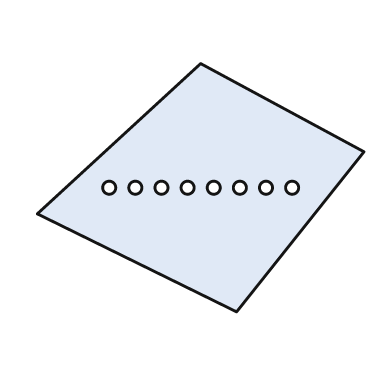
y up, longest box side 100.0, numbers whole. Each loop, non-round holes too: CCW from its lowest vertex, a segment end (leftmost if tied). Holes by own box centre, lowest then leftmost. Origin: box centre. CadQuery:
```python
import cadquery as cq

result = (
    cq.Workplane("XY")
    .moveTo(11.0, -38.0)
    .lineTo(50.0, 11.0)
    .lineTo(0.0, 38.0)
    .lineTo(-50.0, -8.0)
    .close()
    .moveTo(-28.0, 0.0)
    .circle(2.0)
    .moveTo(-20.0, 0.0)
    .circle(2.0)
    .moveTo(-12.0, 0.0)
    .circle(2.0)
    .moveTo(-4.0, 0.0)
    .circle(2.0)
    .moveTo(4.0, 0.0)
    .circle(2.0)
    .moveTo(12.0, 0.0)
    .circle(2.0)
    .moveTo(20.0, 0.0)
    .circle(2.0)
    .moveTo(28.0, 0.0)
    .circle(2.0)
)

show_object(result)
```